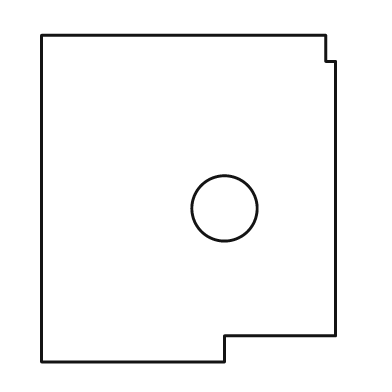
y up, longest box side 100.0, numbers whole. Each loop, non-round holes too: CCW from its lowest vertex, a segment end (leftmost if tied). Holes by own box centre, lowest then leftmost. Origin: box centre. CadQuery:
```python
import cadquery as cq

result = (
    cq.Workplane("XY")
    .moveTo(-45.0, -50.0)
    .lineTo(11.0, -50.0)
    .lineTo(11.0, -42.0)
    .lineTo(45.0, -42.0)
    .lineTo(45.0, 42.0)
    .lineTo(42.0, 42.0)
    .lineTo(42.0, 50.0)
    .lineTo(-45.0, 50.0)
    .close()
    .moveTo(11.0, -3.0)
    .circle(10.0)
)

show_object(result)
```